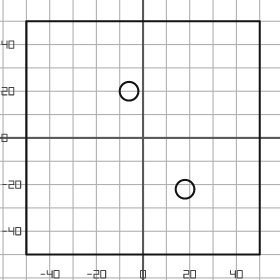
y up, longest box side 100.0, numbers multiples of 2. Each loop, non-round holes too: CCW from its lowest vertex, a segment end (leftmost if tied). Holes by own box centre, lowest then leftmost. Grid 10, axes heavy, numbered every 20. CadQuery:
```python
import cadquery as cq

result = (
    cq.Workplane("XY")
    .moveTo(-50.0, -50.0)
    .lineTo(50.0, -50.0)
    .lineTo(50.0, 50.0)
    .lineTo(-50.0, 50.0)
    .close()
    .moveTo(18.0, -22.0)
    .circle(4.0)
    .moveTo(-6.0, 20.0)
    .circle(4.0)
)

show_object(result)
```